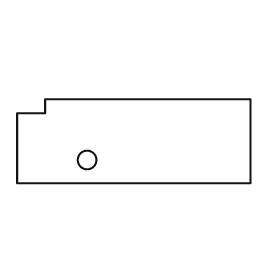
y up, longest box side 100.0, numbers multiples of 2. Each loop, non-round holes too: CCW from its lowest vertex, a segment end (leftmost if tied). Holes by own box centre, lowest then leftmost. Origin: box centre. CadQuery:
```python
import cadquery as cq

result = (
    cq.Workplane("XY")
    .moveTo(-50.0, -18.0)
    .lineTo(50.0, -18.0)
    .lineTo(50.0, 18.0)
    .lineTo(-38.0, 18.0)
    .lineTo(-38.0, 12.0)
    .lineTo(-50.0, 12.0)
    .close()
    .moveTo(-20.0, -8.0)
    .circle(4.0)
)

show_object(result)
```